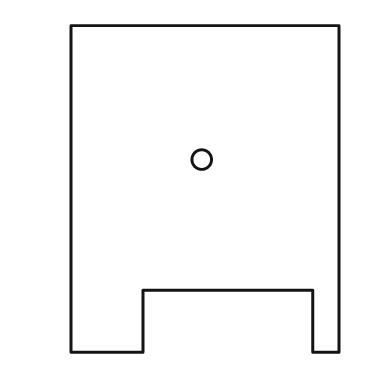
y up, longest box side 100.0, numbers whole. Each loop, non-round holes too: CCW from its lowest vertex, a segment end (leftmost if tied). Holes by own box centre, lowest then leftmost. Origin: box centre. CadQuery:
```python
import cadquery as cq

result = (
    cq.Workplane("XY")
    .moveTo(-41.0, -50.0)
    .lineTo(-19.0, -50.0)
    .lineTo(-19.0, -31.0)
    .lineTo(33.0, -31.0)
    .lineTo(33.0, -50.0)
    .lineTo(41.0, -50.0)
    .lineTo(41.0, 50.0)
    .lineTo(-41.0, 50.0)
    .close()
    .moveTo(-1.0, 9.0)
    .circle(3.0)
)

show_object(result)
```